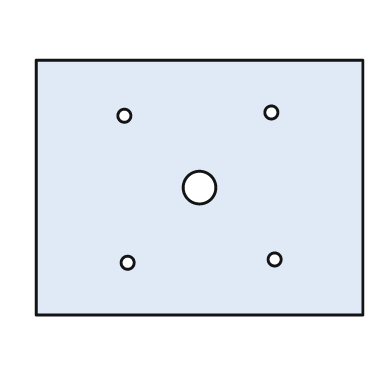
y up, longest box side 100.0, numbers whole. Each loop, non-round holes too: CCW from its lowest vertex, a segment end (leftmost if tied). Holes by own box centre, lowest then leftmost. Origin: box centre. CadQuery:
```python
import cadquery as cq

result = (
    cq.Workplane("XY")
    .moveTo(-50.0, -39.0)
    .lineTo(50.0, -39.0)
    .lineTo(50.0, 39.0)
    .lineTo(-50.0, 39.0)
    .close()
    .moveTo(-22.0, -23.0)
    .circle(2.0)
    .moveTo(23.0, -22.0)
    .circle(2.0)
    .moveTo(0.0, 0.0)
    .circle(5.0)
    .moveTo(-23.0, 22.0)
    .circle(2.0)
    .moveTo(22.0, 23.0)
    .circle(2.0)
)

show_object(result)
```